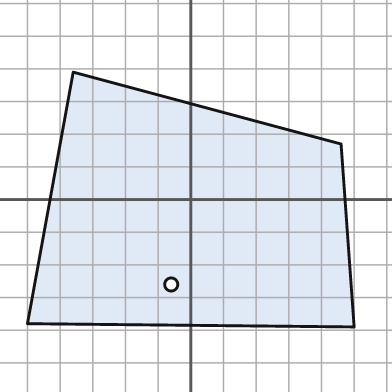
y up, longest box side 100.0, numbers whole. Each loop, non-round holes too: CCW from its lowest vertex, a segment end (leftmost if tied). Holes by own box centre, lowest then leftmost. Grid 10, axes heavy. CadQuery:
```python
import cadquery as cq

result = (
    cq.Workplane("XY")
    .moveTo(50.0, -39.0)
    .lineTo(46.0, 17.0)
    .lineTo(-36.0, 39.0)
    .lineTo(-50.0, -38.0)
    .close()
    .moveTo(-6.0, -26.0)
    .circle(2.0)
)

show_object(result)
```